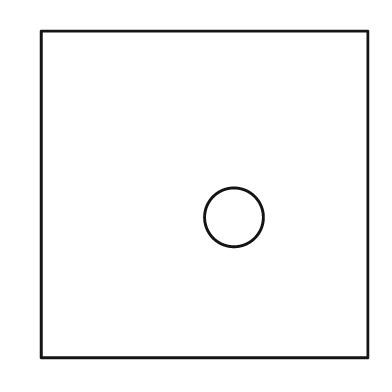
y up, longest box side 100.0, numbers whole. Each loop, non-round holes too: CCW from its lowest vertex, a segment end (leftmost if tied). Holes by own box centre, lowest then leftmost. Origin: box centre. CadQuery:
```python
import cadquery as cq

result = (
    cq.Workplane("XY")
    .moveTo(-50.0, -50.0)
    .lineTo(50.0, -50.0)
    .lineTo(50.0, 50.0)
    .lineTo(-50.0, 50.0)
    .close()
    .moveTo(9.0, -7.0)
    .circle(9.0)
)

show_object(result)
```